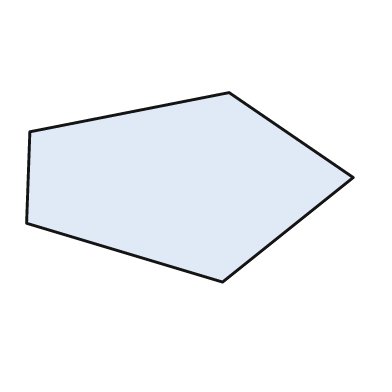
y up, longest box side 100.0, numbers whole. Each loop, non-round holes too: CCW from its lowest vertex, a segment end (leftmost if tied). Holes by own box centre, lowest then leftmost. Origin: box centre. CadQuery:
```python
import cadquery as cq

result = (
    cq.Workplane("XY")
    .moveTo(10.0, -29.0)
    .lineTo(50.0, 3.0)
    .lineTo(12.0, 29.0)
    .lineTo(-49.0, 17.0)
    .lineTo(-50.0, -11.0)
    .close()
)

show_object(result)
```